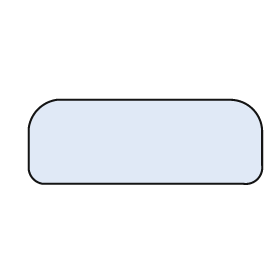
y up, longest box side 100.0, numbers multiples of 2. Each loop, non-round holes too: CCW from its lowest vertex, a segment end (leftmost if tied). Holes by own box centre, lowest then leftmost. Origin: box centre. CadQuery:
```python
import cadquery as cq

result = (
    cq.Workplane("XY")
    .moveTo(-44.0, -18.0)
    .lineTo(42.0, -18.0)
    .threePointArc((48.0, -16.0), (50.0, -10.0))
    .lineTo(50.0, 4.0)
    .threePointArc((46.0, 14.0), (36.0, 18.0))
    .lineTo(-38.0, 18.0)
    .threePointArc((-46.0, 14.0), (-50.0, 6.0))
    .lineTo(-50.0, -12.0)
    .threePointArc((-48.0, -16.0), (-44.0, -18.0))
    .close()
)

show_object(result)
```